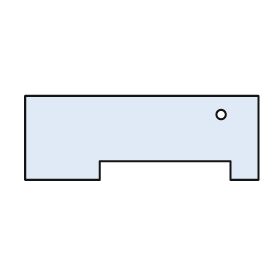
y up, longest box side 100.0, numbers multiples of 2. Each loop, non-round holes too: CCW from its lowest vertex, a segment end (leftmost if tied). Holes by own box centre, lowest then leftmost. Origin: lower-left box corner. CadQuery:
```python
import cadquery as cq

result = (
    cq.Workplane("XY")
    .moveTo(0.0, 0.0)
    .lineTo(32.0, 0.0)
    .lineTo(32.0, 8.0)
    .lineTo(88.0, 8.0)
    .lineTo(88.0, 0.0)
    .lineTo(100.0, 0.0)
    .lineTo(100.0, 36.0)
    .lineTo(0.0, 36.0)
    .close()
    .moveTo(84.0, 28.0)
    .circle(2.0)
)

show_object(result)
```